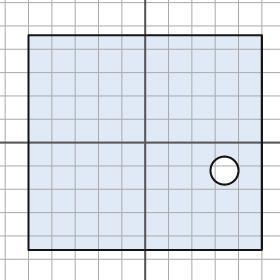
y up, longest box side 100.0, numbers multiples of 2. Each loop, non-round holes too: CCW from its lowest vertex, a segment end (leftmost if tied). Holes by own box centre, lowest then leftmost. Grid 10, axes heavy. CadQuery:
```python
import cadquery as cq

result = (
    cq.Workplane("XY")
    .moveTo(-50.0, -46.0)
    .lineTo(50.0, -46.0)
    .lineTo(50.0, 46.0)
    .lineTo(-50.0, 46.0)
    .close()
    .moveTo(34.0, -12.0)
    .circle(6.0)
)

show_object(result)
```